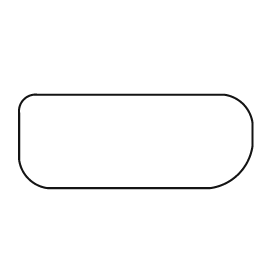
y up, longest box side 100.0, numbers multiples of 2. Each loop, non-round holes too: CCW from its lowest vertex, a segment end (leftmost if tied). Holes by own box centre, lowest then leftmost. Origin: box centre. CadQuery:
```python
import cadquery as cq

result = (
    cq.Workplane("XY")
    .moveTo(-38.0, -20.0)
    .lineTo(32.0, -20.0)
    .threePointArc((44.0, -14.0), (50.0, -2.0))
    .lineTo(50.0, 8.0)
    .threePointArc((46.0, 16.0), (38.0, 20.0))
    .lineTo(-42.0, 20.0)
    .threePointArc((-48.0, 18.0), (-50.0, 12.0))
    .lineTo(-50.0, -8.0)
    .threePointArc((-46.0, -16.0), (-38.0, -20.0))
    .close()
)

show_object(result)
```